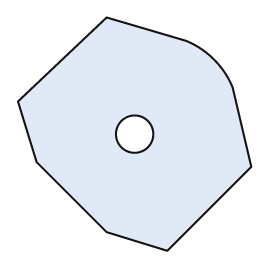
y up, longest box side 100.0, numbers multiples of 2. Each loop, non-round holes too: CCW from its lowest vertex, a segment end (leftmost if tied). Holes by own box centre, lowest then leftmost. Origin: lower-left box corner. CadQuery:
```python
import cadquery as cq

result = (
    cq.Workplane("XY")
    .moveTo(64.0, 0.0)
    .lineTo(100.0, 36.0)
    .lineTo(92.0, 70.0)
    .threePointArc((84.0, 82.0), (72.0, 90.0))
    .lineTo(38.0, 100.0)
    .lineTo(0.0, 64.0)
    .lineTo(8.0, 38.0)
    .lineTo(38.0, 8.0)
    .close()
    .moveTo(50.0, 50.0)
    .circle(8.0)
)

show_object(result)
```